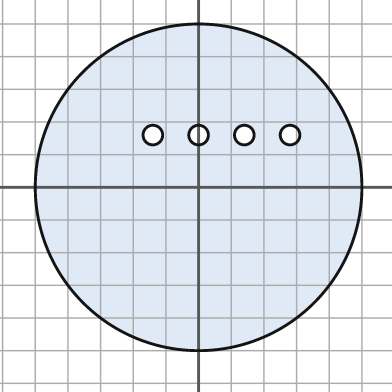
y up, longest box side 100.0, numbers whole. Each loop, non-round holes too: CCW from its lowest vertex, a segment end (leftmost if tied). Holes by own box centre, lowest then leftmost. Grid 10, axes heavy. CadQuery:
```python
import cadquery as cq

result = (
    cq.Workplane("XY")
    .moveTo(0.0, 0.0)
    .circle(50.0)
    .moveTo(-14.0, 16.0)
    .circle(3.0)
    .moveTo(0.0, 16.0)
    .circle(3.0)
    .moveTo(14.0, 16.0)
    .circle(3.0)
    .moveTo(28.0, 16.0)
    .circle(3.0)
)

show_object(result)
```